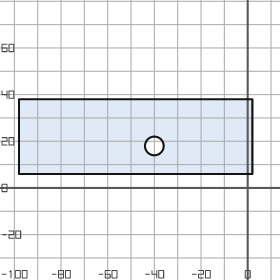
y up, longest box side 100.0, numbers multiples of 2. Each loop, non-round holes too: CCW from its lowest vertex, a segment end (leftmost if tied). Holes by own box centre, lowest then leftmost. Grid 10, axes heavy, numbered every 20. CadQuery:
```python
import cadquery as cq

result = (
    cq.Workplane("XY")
    .moveTo(-98.0, 6.0)
    .lineTo(2.0, 6.0)
    .lineTo(2.0, 38.0)
    .lineTo(-98.0, 38.0)
    .close()
    .moveTo(-40.0, 18.0)
    .circle(4.0)
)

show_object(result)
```